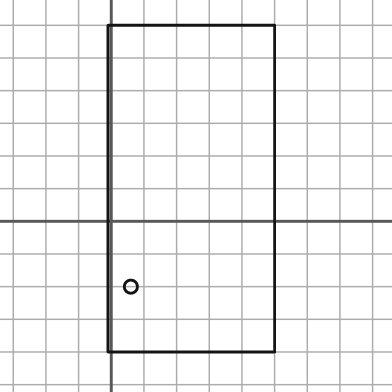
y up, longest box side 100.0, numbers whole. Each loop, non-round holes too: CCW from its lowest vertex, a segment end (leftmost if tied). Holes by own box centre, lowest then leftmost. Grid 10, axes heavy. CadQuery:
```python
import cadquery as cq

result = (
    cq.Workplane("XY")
    .moveTo(-1.0, -40.0)
    .lineTo(50.0, -40.0)
    .lineTo(50.0, 60.0)
    .lineTo(-1.0, 60.0)
    .close()
    .moveTo(6.0, -20.0)
    .circle(2.0)
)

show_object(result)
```